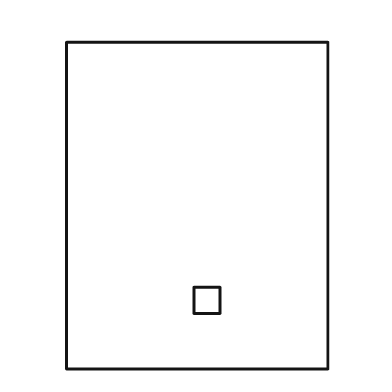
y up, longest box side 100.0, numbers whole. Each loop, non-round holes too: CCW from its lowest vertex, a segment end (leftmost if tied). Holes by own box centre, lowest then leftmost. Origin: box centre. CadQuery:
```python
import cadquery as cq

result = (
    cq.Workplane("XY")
    .moveTo(-40.0, -50.0)
    .lineTo(40.0, -50.0)
    .lineTo(40.0, 50.0)
    .lineTo(-40.0, 50.0)
    .close()
    .moveTo(-1.0, -33.0)
    .lineTo(7.0, -33.0)
    .lineTo(7.0, -25.0)
    .lineTo(-1.0, -25.0)
    .close()
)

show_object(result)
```